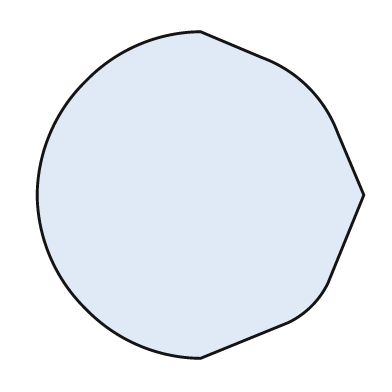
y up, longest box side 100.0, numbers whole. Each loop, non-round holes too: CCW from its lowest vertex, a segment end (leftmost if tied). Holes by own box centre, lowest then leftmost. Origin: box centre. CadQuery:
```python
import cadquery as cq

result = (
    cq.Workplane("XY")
    .moveTo(0.0, -50.0)
    .lineTo(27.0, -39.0)
    .threePointArc((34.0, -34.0), (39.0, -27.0))
    .lineTo(50.0, 0.0)
    .lineTo(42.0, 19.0)
    .threePointArc((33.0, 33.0), (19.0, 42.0))
    .lineTo(0.0, 50.0)
    .threePointArc((-19.0, 46.0), (-35.0, 35.0))
    .threePointArc((-46.0, 19.0), (-50.0, 0.0))
    .threePointArc((-46.0, -19.0), (-35.0, -35.0))
    .threePointArc((-19.0, -46.0), (0.0, -50.0))
    .close()
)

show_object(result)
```